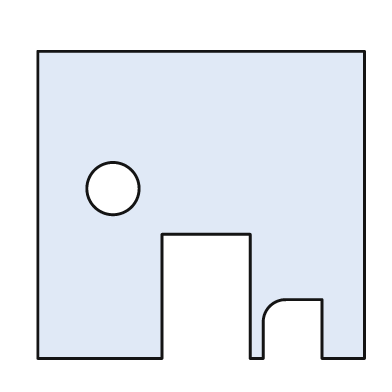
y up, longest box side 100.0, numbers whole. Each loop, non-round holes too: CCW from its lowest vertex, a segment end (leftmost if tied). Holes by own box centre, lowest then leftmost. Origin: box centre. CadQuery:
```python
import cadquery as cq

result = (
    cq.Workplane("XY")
    .moveTo(-50.0, -47.0)
    .lineTo(-12.0, -47.0)
    .lineTo(-12.0, -9.0)
    .lineTo(15.0, -9.0)
    .lineTo(15.0, -47.0)
    .lineTo(19.0, -47.0)
    .lineTo(19.0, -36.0)
    .threePointArc((21.0, -31.0), (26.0, -29.0))
    .lineTo(37.0, -29.0)
    .lineTo(37.0, -47.0)
    .lineTo(50.0, -47.0)
    .lineTo(50.0, 47.0)
    .lineTo(-50.0, 47.0)
    .close()
    .moveTo(-27.0, 5.0)
    .circle(8.0)
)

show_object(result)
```